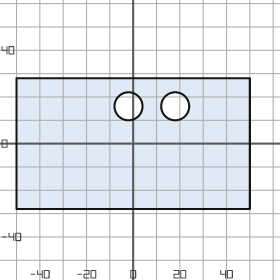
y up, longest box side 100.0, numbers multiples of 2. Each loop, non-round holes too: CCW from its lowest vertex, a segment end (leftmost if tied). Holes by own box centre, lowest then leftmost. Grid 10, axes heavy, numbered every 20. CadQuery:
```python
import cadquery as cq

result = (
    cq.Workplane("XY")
    .moveTo(-50.0, -28.0)
    .lineTo(50.0, -28.0)
    .lineTo(50.0, 28.0)
    .lineTo(-50.0, 28.0)
    .close()
    .moveTo(-2.0, 16.0)
    .circle(6.0)
    .moveTo(18.0, 16.0)
    .circle(6.0)
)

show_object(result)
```